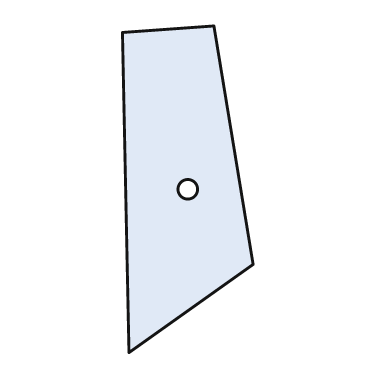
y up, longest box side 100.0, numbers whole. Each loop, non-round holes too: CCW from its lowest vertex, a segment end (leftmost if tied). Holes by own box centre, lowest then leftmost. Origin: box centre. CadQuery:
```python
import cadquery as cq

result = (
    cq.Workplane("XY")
    .moveTo(-18.0, -50.0)
    .lineTo(20.0, -23.0)
    .lineTo(8.0, 50.0)
    .lineTo(-20.0, 48.0)
    .close()
    .moveTo(0.0, 0.0)
    .circle(3.0)
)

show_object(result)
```